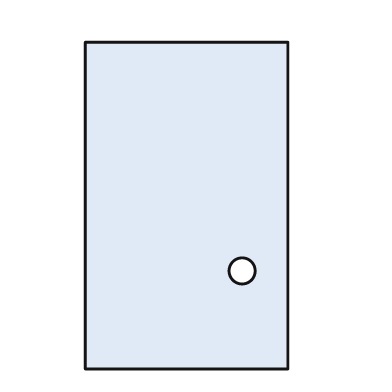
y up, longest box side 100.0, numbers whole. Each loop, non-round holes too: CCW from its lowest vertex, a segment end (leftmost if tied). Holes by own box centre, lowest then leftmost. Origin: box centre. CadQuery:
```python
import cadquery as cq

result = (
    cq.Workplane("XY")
    .moveTo(-31.0, -50.0)
    .lineTo(31.0, -50.0)
    .lineTo(31.0, 50.0)
    .lineTo(-31.0, 50.0)
    .close()
    .moveTo(17.0, -20.0)
    .circle(4.0)
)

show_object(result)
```